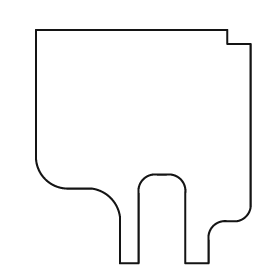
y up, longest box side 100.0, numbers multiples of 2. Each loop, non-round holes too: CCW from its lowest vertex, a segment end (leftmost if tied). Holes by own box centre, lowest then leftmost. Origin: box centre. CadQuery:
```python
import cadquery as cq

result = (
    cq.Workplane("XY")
    .moveTo(-10.0, -50.0)
    .lineTo(-2.0, -50.0)
    .lineTo(-2.0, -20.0)
    .threePointArc((0.0, -14.0), (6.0, -12.0))
    .lineTo(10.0, -12.0)
    .threePointArc((16.0, -14.0), (18.0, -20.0))
    .lineTo(18.0, -50.0)
    .lineTo(28.0, -50.0)
    .lineTo(28.0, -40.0)
    .threePointArc((30.0, -34.0), (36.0, -32.0))
    .lineTo(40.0, -32.0)
    .threePointArc((44.0, -30.0), (46.0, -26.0))
    .lineTo(46.0, 44.0)
    .lineTo(36.0, 44.0)
    .lineTo(36.0, 50.0)
    .lineTo(-46.0, 50.0)
    .lineTo(-46.0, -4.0)
    .threePointArc((-42.0, -14.0), (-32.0, -18.0))
    .lineTo(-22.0, -18.0)
    .threePointArc((-14.0, -22.0), (-10.0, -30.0))
    .close()
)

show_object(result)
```